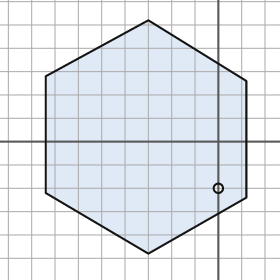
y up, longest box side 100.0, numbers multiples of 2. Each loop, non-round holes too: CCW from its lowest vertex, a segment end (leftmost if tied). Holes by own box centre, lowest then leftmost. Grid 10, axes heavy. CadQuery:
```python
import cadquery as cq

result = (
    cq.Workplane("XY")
    .moveTo(-30.0, -48.0)
    .lineTo(12.0, -24.0)
    .lineTo(12.0, 26.0)
    .lineTo(-30.0, 52.0)
    .lineTo(-74.0, 28.0)
    .lineTo(-74.0, -22.0)
    .close()
    .moveTo(0.0, -20.0)
    .circle(2.0)
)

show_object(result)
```